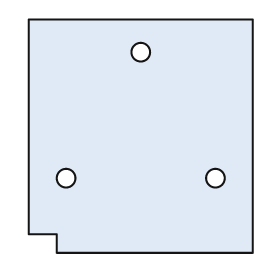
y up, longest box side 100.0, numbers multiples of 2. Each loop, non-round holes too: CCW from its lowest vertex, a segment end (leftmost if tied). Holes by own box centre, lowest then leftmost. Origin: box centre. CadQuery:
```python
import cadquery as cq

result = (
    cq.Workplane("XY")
    .moveTo(-36.0, -50.0)
    .lineTo(48.0, -50.0)
    .lineTo(48.0, 50.0)
    .lineTo(-48.0, 50.0)
    .lineTo(-48.0, -42.0)
    .lineTo(-36.0, -42.0)
    .close()
    .moveTo(-32.0, -18.0)
    .circle(4.0)
    .moveTo(32.0, -18.0)
    .circle(4.0)
    .moveTo(0.0, 36.0)
    .circle(4.0)
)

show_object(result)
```